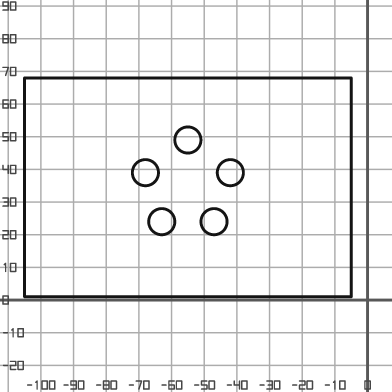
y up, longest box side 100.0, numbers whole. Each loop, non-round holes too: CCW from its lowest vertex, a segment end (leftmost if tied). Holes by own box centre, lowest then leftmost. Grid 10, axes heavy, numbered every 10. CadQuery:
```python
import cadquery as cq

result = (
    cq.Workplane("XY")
    .moveTo(-105.0, 1.0)
    .lineTo(-5.0, 1.0)
    .lineTo(-5.0, 68.0)
    .lineTo(-105.0, 68.0)
    .close()
    .moveTo(-63.0, 24.0)
    .circle(4.0)
    .moveTo(-47.0, 24.0)
    .circle(4.0)
    .moveTo(-68.0, 39.0)
    .circle(4.0)
    .moveTo(-42.0, 39.0)
    .circle(4.0)
    .moveTo(-55.0, 49.0)
    .circle(4.0)
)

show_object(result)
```